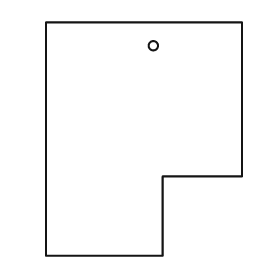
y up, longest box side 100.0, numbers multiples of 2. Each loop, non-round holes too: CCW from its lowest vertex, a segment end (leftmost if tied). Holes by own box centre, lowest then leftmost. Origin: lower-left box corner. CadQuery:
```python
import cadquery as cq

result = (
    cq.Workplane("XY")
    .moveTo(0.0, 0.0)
    .lineTo(50.0, 0.0)
    .lineTo(50.0, 34.0)
    .lineTo(84.0, 34.0)
    .lineTo(84.0, 100.0)
    .lineTo(0.0, 100.0)
    .close()
    .moveTo(46.0, 90.0)
    .circle(2.0)
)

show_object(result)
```